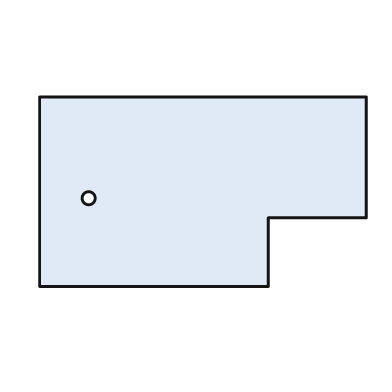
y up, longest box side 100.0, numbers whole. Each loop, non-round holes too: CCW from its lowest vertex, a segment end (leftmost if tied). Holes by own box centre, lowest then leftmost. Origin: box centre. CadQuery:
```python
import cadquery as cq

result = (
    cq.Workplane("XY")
    .moveTo(-50.0, -29.0)
    .lineTo(20.0, -29.0)
    .lineTo(20.0, -8.0)
    .lineTo(50.0, -8.0)
    .lineTo(50.0, 29.0)
    .lineTo(-50.0, 29.0)
    .close()
    .moveTo(-35.0, -2.0)
    .circle(2.0)
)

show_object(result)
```